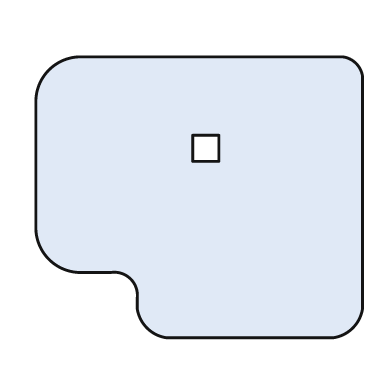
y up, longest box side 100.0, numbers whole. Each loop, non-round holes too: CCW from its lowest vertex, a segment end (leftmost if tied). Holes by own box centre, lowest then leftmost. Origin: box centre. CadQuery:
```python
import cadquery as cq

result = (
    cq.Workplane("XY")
    .moveTo(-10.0, -43.0)
    .lineTo(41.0, -43.0)
    .threePointArc((47.0, -40.0), (50.0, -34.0))
    .lineTo(50.0, 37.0)
    .threePointArc((48.0, 41.0), (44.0, 43.0))
    .lineTo(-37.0, 43.0)
    .threePointArc((-46.0, 39.0), (-50.0, 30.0))
    .lineTo(-50.0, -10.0)
    .threePointArc((-46.0, -19.0), (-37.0, -23.0))
    .lineTo(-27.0, -23.0)
    .threePointArc((-21.0, -25.0), (-19.0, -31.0))
    .lineTo(-19.0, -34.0)
    .threePointArc((-16.0, -40.0), (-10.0, -43.0))
    .close()
    .moveTo(-2.0, 11.0)
    .lineTo(6.0, 11.0)
    .lineTo(6.0, 19.0)
    .lineTo(-2.0, 19.0)
    .close()
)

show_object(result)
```